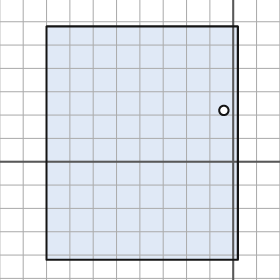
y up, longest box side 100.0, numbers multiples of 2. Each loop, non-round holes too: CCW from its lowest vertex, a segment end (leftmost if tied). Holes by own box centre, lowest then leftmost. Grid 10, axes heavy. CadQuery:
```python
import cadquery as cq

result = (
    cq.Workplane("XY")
    .moveTo(-80.0, -42.0)
    .lineTo(2.0, -42.0)
    .lineTo(2.0, 58.0)
    .lineTo(-80.0, 58.0)
    .close()
    .moveTo(-4.0, 22.0)
    .circle(2.0)
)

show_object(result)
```